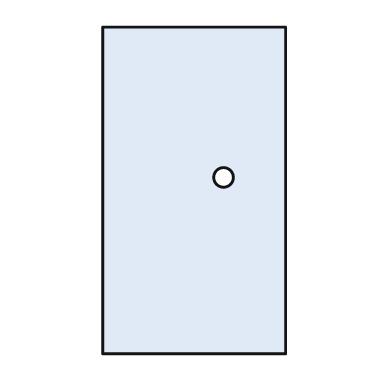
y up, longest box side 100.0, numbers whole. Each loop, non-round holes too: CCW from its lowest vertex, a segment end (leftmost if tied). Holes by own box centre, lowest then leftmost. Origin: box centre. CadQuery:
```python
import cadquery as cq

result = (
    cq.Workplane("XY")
    .moveTo(-28.0, -50.0)
    .lineTo(28.0, -50.0)
    .lineTo(28.0, 50.0)
    .lineTo(-28.0, 50.0)
    .close()
    .moveTo(9.0, 4.0)
    .circle(3.0)
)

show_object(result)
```